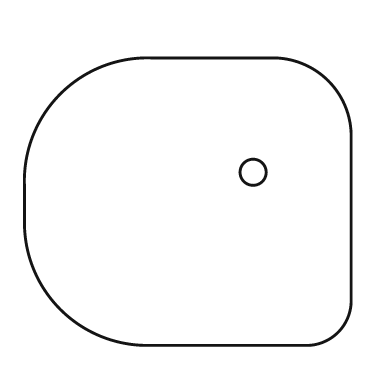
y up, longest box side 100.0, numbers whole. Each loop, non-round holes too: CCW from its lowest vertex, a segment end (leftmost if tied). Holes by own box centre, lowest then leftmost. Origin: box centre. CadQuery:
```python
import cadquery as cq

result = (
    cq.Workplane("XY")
    .moveTo(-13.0, -44.0)
    .lineTo(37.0, -44.0)
    .threePointArc((46.0, -40.0), (50.0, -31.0))
    .lineTo(50.0, 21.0)
    .threePointArc((43.0, 37.0), (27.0, 44.0))
    .lineTo(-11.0, 44.0)
    .threePointArc((-39.0, 33.0), (-50.0, 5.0))
    .lineTo(-50.0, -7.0)
    .threePointArc((-39.0, -33.0), (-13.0, -44.0))
    .close()
    .moveTo(20.0, 9.0)
    .circle(4.0)
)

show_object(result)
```